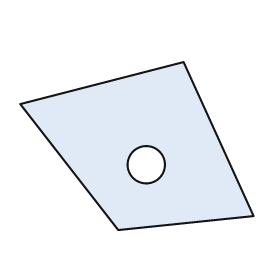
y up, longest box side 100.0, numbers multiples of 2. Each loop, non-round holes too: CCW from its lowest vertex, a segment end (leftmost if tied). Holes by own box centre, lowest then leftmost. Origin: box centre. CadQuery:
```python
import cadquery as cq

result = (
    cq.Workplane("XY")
    .moveTo(-8.0, -36.0)
    .lineTo(50.0, -30.0)
    .lineTo(20.0, 36.0)
    .lineTo(-50.0, 18.0)
    .close()
    .moveTo(4.0, -8.0)
    .circle(8.0)
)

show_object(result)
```